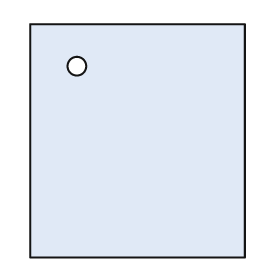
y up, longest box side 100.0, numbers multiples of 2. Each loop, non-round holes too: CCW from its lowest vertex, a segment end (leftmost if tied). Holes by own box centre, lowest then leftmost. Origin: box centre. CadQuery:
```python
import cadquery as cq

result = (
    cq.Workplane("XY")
    .moveTo(-46.0, -50.0)
    .lineTo(46.0, -50.0)
    .lineTo(46.0, 50.0)
    .lineTo(-46.0, 50.0)
    .close()
    .moveTo(-26.0, 32.0)
    .circle(4.0)
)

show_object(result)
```